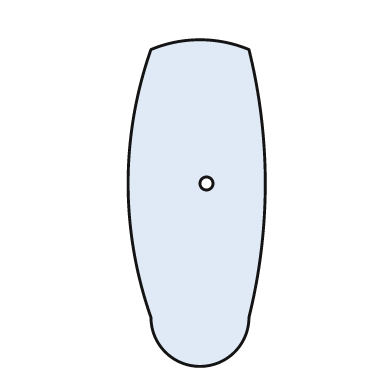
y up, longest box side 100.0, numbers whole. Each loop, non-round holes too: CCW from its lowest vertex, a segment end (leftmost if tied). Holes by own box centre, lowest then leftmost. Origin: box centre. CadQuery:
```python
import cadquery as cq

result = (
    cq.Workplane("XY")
    .moveTo(-14.0, -35.0)
    .threePointArc((1.0, -50.0), (16.0, -35.0))
    .threePointArc((21.0, 6.0), (16.0, 47.0))
    .threePointArc((1.0, 50.0), (-14.0, 47.0))
    .threePointArc((-21.0, 6.0), (-14.0, -35.0))
    .close()
    .moveTo(3.0, 6.0)
    .circle(2.0)
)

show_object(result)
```